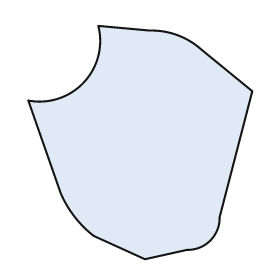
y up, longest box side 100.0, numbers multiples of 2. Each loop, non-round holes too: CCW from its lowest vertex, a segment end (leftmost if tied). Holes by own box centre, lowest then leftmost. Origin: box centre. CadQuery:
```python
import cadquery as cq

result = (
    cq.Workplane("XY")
    .moveTo(2.0, -50.0)
    .lineTo(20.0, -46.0)
    .threePointArc((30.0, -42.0), (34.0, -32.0))
    .lineTo(48.0, 22.0)
    .lineTo(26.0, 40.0)
    .threePointArc((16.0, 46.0), (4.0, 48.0))
    .lineTo(-18.0, 50.0)
    .threePointArc((-24.0, 26.0), (-48.0, 18.0))
    .lineTo(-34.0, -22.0)
    .threePointArc((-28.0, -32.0), (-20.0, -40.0))
    .close()
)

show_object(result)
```